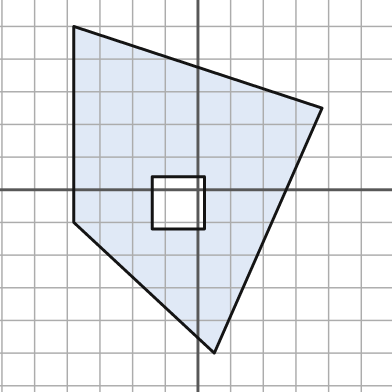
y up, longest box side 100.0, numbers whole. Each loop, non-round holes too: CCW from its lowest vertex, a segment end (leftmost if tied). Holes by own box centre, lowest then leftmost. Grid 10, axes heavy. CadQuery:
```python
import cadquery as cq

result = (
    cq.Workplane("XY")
    .moveTo(5.0, -50.0)
    .lineTo(38.0, 25.0)
    .lineTo(-38.0, 50.0)
    .lineTo(-38.0, -10.0)
    .close()
    .moveTo(-14.0, -12.0)
    .lineTo(2.0, -12.0)
    .lineTo(2.0, 4.0)
    .lineTo(-14.0, 4.0)
    .close()
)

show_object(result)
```